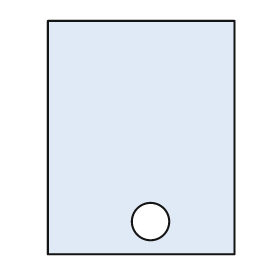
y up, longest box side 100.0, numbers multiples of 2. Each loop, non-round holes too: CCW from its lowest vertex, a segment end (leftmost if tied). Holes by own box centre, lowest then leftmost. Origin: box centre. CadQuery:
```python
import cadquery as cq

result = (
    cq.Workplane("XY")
    .moveTo(-40.0, -50.0)
    .lineTo(40.0, -50.0)
    .lineTo(40.0, 50.0)
    .lineTo(-40.0, 50.0)
    .close()
    .moveTo(4.0, -36.0)
    .circle(8.0)
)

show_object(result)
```